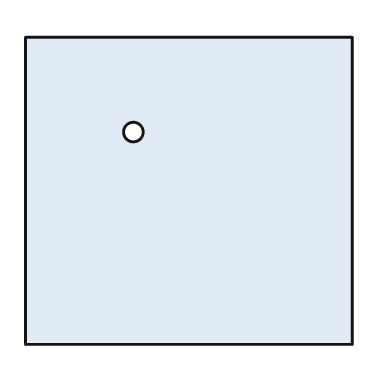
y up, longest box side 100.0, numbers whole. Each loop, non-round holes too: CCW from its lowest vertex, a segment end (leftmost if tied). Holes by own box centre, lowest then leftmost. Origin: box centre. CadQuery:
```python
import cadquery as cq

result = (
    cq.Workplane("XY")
    .moveTo(-50.0, -47.0)
    .lineTo(50.0, -47.0)
    .lineTo(50.0, 47.0)
    .lineTo(-50.0, 47.0)
    .close()
    .moveTo(-17.0, 18.0)
    .circle(3.0)
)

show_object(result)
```